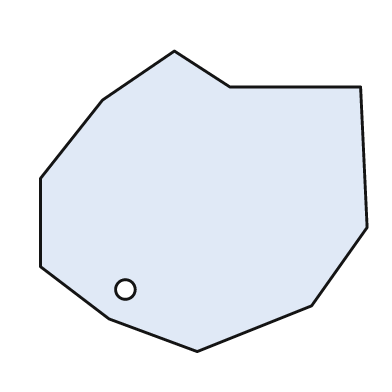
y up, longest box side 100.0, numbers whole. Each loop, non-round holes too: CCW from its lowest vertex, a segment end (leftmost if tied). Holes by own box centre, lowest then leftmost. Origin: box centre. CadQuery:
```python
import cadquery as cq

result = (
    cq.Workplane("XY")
    .moveTo(-2.0, -46.0)
    .lineTo(33.0, -32.0)
    .lineTo(50.0, -8.0)
    .lineTo(48.0, 35.0)
    .lineTo(8.0, 35.0)
    .lineTo(-9.0, 46.0)
    .lineTo(-31.0, 31.0)
    .lineTo(-50.0, 7.0)
    .lineTo(-50.0, -20.0)
    .lineTo(-29.0, -36.0)
    .close()
    .moveTo(-24.0, -27.0)
    .circle(3.0)
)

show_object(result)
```